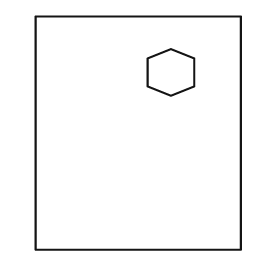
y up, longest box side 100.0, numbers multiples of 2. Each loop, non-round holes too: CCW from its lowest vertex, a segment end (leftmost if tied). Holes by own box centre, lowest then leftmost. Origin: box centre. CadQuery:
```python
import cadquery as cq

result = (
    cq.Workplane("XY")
    .moveTo(-44.0, -50.0)
    .lineTo(44.0, -50.0)
    .lineTo(44.0, 50.0)
    .lineTo(-44.0, 50.0)
    .close()
    .moveTo(14.0, 16.0)
    .lineTo(24.0, 20.0)
    .lineTo(24.0, 32.0)
    .lineTo(14.0, 36.0)
    .lineTo(4.0, 32.0)
    .lineTo(4.0, 20.0)
    .close()
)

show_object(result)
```